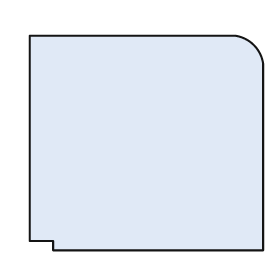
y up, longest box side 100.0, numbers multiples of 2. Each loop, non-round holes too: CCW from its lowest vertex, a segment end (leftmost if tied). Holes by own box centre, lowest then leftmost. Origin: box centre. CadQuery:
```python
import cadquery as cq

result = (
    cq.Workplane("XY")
    .moveTo(-40.0, -46.0)
    .lineTo(50.0, -46.0)
    .lineTo(50.0, 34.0)
    .threePointArc((46.0, 42.0), (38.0, 46.0))
    .lineTo(-50.0, 46.0)
    .lineTo(-50.0, -42.0)
    .lineTo(-40.0, -42.0)
    .close()
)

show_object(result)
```